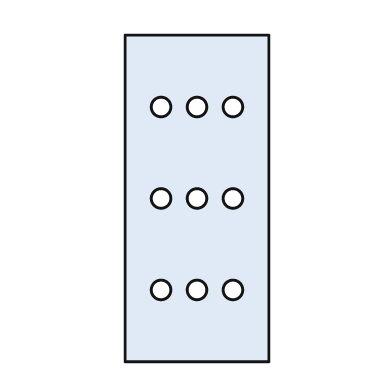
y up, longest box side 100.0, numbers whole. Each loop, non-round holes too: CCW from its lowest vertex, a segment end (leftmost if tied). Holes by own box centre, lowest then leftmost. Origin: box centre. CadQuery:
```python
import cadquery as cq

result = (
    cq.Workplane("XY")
    .moveTo(-22.0, -50.0)
    .lineTo(22.0, -50.0)
    .lineTo(22.0, 50.0)
    .lineTo(-22.0, 50.0)
    .close()
    .moveTo(-11.0, -28.0)
    .circle(3.0)
    .moveTo(0.0, -28.0)
    .circle(3.0)
    .moveTo(11.0, -28.0)
    .circle(3.0)
    .moveTo(-11.0, 0.0)
    .circle(3.0)
    .moveTo(0.0, 0.0)
    .circle(3.0)
    .moveTo(11.0, 0.0)
    .circle(3.0)
    .moveTo(-11.0, 28.0)
    .circle(3.0)
    .moveTo(0.0, 28.0)
    .circle(3.0)
    .moveTo(11.0, 28.0)
    .circle(3.0)
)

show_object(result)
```